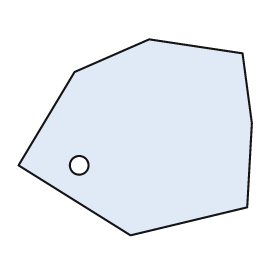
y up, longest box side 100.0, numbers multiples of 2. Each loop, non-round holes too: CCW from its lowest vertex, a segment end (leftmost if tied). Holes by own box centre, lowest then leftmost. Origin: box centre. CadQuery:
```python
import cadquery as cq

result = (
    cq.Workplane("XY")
    .moveTo(-2.0, -42.0)
    .lineTo(48.0, -30.0)
    .lineTo(50.0, 6.0)
    .lineTo(46.0, 36.0)
    .lineTo(6.0, 42.0)
    .lineTo(-26.0, 28.0)
    .lineTo(-50.0, -12.0)
    .close()
    .moveTo(-24.0, -12.0)
    .circle(4.0)
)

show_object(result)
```